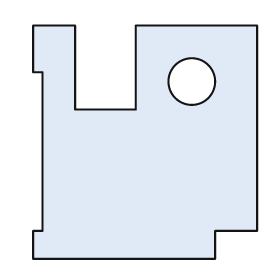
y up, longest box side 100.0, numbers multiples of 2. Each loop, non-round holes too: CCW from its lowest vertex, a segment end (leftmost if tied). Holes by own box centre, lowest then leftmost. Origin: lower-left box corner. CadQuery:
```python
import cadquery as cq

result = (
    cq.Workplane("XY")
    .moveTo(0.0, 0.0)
    .lineTo(78.0, 0.0)
    .lineTo(78.0, 12.0)
    .lineTo(96.0, 12.0)
    .lineTo(96.0, 100.0)
    .lineTo(44.0, 100.0)
    .lineTo(44.0, 64.0)
    .lineTo(18.0, 64.0)
    .lineTo(18.0, 100.0)
    .lineTo(0.0, 100.0)
    .lineTo(0.0, 80.0)
    .lineTo(4.0, 80.0)
    .lineTo(4.0, 12.0)
    .lineTo(0.0, 12.0)
    .close()
    .moveTo(68.0, 76.0)
    .circle(10.0)
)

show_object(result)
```